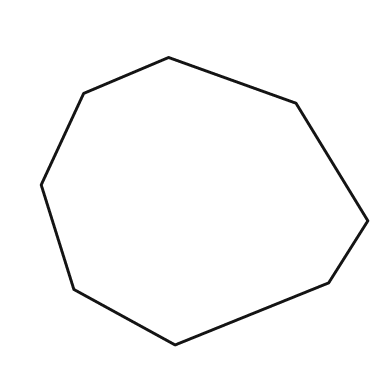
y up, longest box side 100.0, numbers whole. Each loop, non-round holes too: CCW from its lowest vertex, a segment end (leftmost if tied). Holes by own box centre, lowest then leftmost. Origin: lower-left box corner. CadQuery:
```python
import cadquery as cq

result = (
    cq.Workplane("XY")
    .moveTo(41.0, 0.0)
    .lineTo(88.0, 19.0)
    .lineTo(100.0, 38.0)
    .lineTo(78.0, 74.0)
    .lineTo(39.0, 88.0)
    .lineTo(13.0, 77.0)
    .lineTo(0.0, 49.0)
    .lineTo(10.0, 17.0)
    .close()
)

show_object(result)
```